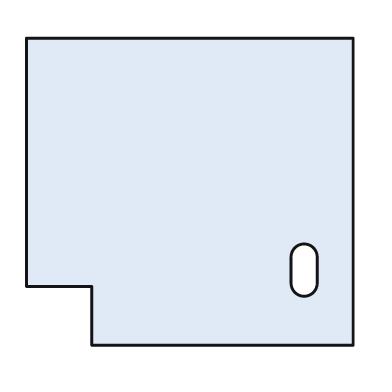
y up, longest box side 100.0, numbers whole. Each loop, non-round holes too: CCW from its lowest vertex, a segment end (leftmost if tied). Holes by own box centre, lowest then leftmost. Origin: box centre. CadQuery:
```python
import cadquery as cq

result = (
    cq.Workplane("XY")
    .moveTo(-30.0, -47.0)
    .lineTo(50.0, -47.0)
    .lineTo(50.0, 47.0)
    .lineTo(-50.0, 47.0)
    .lineTo(-50.0, -29.0)
    .lineTo(-30.0, -29.0)
    .close()
    .moveTo(31.0, -28.0)
    .threePointArc((35.0, -32.0), (39.0, -28.0))
    .lineTo(39.0, -20.0)
    .threePointArc((35.0, -16.0), (31.0, -20.0))
    .close()
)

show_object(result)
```